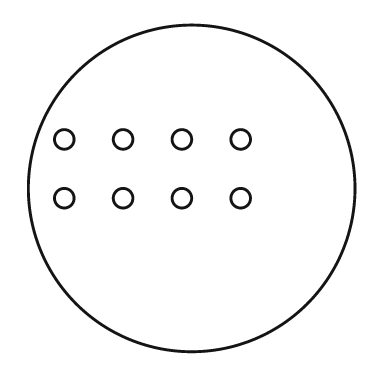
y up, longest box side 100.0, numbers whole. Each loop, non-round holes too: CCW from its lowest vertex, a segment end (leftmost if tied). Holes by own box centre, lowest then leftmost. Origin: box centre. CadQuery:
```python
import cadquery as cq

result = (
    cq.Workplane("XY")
    .moveTo(0.0, 0.0)
    .circle(50.0)
    .moveTo(-39.0, -3.0)
    .circle(3.0)
    .moveTo(-21.0, -3.0)
    .circle(3.0)
    .moveTo(-3.0, -3.0)
    .circle(3.0)
    .moveTo(15.0, -3.0)
    .circle(3.0)
    .moveTo(-39.0, 15.0)
    .circle(3.0)
    .moveTo(-21.0, 15.0)
    .circle(3.0)
    .moveTo(-3.0, 15.0)
    .circle(3.0)
    .moveTo(15.0, 15.0)
    .circle(3.0)
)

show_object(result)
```